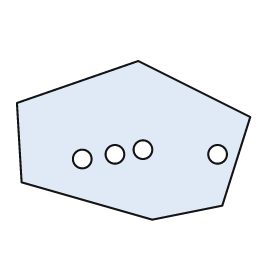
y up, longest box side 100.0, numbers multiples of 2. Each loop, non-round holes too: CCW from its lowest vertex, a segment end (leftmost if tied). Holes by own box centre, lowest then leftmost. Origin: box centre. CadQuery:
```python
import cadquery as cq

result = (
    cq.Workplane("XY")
    .moveTo(8.0, -34.0)
    .lineTo(38.0, -28.0)
    .lineTo(50.0, 10.0)
    .lineTo(2.0, 34.0)
    .lineTo(-50.0, 16.0)
    .lineTo(-48.0, -18.0)
    .close()
    .moveTo(-22.0, -8.0)
    .circle(4.0)
    .moveTo(-8.0, -6.0)
    .circle(4.0)
    .moveTo(36.0, -6.0)
    .circle(4.0)
    .moveTo(4.0, -4.0)
    .circle(4.0)
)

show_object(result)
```